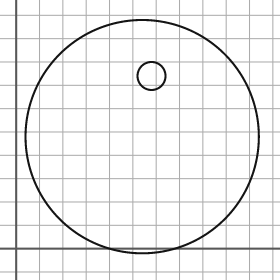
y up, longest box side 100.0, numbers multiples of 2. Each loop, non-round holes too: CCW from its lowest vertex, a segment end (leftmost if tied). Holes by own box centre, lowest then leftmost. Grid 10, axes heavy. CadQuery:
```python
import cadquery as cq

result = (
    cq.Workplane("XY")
    .moveTo(54.0, 48.0)
    .circle(50.0)
    .moveTo(58.0, 74.0)
    .circle(6.0)
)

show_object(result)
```